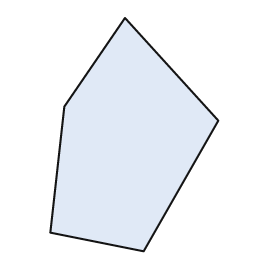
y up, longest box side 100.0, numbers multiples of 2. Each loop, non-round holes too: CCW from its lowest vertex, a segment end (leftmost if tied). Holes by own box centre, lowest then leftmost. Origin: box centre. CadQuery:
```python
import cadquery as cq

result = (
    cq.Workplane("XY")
    .moveTo(4.0, -50.0)
    .lineTo(36.0, 6.0)
    .lineTo(-4.0, 50.0)
    .lineTo(-30.0, 12.0)
    .lineTo(-36.0, -42.0)
    .close()
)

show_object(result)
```